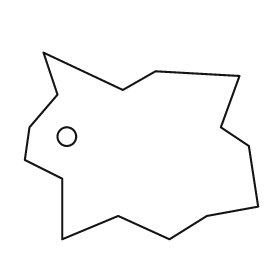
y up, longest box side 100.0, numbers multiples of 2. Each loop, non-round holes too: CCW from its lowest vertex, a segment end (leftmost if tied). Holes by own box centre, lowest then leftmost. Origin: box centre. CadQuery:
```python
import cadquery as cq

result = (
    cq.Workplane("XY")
    .moveTo(-34.0, -40.0)
    .lineTo(-10.0, -30.0)
    .lineTo(12.0, -40.0)
    .lineTo(28.0, -30.0)
    .lineTo(50.0, -26.0)
    .lineTo(46.0, 0.0)
    .lineTo(34.0, 8.0)
    .lineTo(42.0, 30.0)
    .lineTo(6.0, 32.0)
    .lineTo(-8.0, 24.0)
    .lineTo(-42.0, 40.0)
    .lineTo(-36.0, 22.0)
    .lineTo(-48.0, 8.0)
    .lineTo(-50.0, -6.0)
    .lineTo(-34.0, -14.0)
    .close()
    .moveTo(-32.0, 4.0)
    .circle(4.0)
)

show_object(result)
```